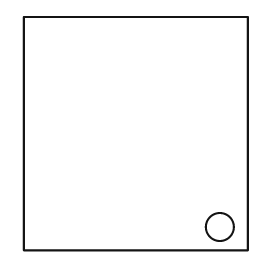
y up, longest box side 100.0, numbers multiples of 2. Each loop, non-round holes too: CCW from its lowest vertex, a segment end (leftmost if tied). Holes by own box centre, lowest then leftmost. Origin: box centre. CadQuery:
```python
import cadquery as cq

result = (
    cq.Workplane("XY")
    .moveTo(-48.0, -50.0)
    .lineTo(48.0, -50.0)
    .lineTo(48.0, 50.0)
    .lineTo(-48.0, 50.0)
    .close()
    .moveTo(36.0, -40.0)
    .circle(6.0)
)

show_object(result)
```